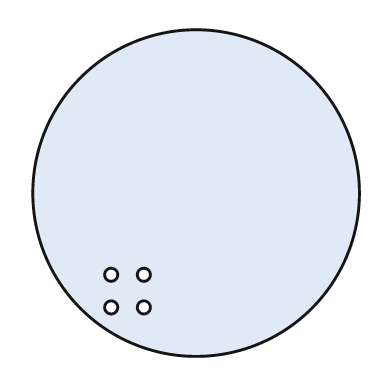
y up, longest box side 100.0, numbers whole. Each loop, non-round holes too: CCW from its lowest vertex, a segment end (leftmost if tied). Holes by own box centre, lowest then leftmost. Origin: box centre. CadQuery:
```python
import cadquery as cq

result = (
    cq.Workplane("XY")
    .moveTo(0.0, 0.0)
    .circle(50.0)
    .moveTo(-26.0, -35.0)
    .circle(2.0)
    .moveTo(-16.0, -35.0)
    .circle(2.0)
    .moveTo(-26.0, -25.0)
    .circle(2.0)
    .moveTo(-16.0, -25.0)
    .circle(2.0)
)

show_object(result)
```